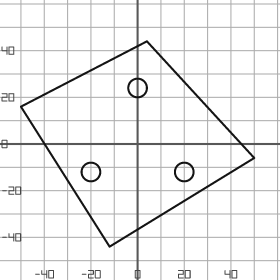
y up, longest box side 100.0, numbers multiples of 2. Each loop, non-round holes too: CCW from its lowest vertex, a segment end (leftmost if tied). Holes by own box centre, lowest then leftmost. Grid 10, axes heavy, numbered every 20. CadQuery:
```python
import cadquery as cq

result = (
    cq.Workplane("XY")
    .moveTo(-12.0, -44.0)
    .lineTo(50.0, -6.0)
    .lineTo(4.0, 44.0)
    .lineTo(-50.0, 16.0)
    .close()
    .moveTo(-20.0, -12.0)
    .circle(4.0)
    .moveTo(20.0, -12.0)
    .circle(4.0)
    .moveTo(0.0, 24.0)
    .circle(4.0)
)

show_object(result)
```